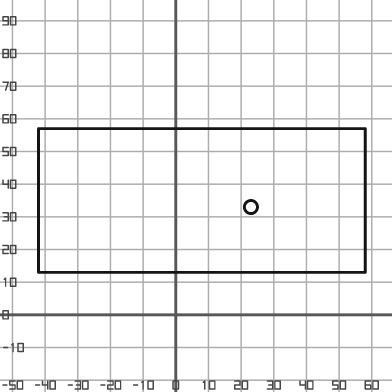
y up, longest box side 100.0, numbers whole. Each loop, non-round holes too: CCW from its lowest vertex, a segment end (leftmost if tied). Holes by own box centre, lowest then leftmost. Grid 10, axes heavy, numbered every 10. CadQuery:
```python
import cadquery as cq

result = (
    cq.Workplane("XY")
    .moveTo(-42.0, 13.0)
    .lineTo(58.0, 13.0)
    .lineTo(58.0, 57.0)
    .lineTo(-42.0, 57.0)
    .close()
    .moveTo(23.0, 33.0)
    .circle(2.0)
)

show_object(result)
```